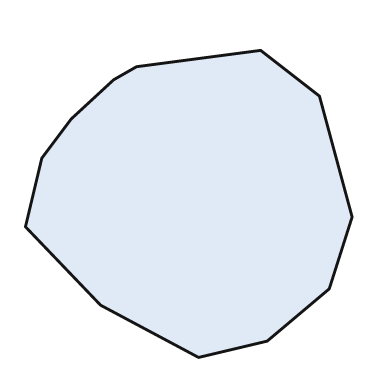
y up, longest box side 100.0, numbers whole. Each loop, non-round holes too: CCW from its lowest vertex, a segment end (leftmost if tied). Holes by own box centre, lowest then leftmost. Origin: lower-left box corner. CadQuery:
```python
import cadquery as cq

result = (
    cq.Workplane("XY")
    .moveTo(53.0, 0.0)
    .lineTo(74.0, 5.0)
    .lineTo(93.0, 21.0)
    .lineTo(100.0, 43.0)
    .lineTo(90.0, 80.0)
    .lineTo(72.0, 94.0)
    .lineTo(34.0, 89.0)
    .lineTo(27.0, 85.0)
    .lineTo(14.0, 73.0)
    .lineTo(5.0, 61.0)
    .lineTo(0.0, 40.0)
    .lineTo(23.0, 16.0)
    .close()
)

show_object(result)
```